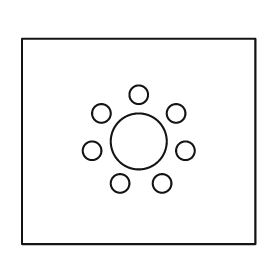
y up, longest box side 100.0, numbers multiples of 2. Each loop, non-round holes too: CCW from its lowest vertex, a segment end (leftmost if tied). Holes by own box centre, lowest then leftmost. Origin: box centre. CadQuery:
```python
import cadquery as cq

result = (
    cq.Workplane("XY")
    .moveTo(-50.0, -44.0)
    .lineTo(50.0, -44.0)
    .lineTo(50.0, 44.0)
    .lineTo(-50.0, 44.0)
    .close()
    .moveTo(-8.0, -18.0)
    .circle(4.0)
    .moveTo(10.0, -18.0)
    .circle(4.0)
    .moveTo(-20.0, -4.0)
    .circle(4.0)
    .moveTo(20.0, -4.0)
    .circle(4.0)
    .moveTo(0.0, 0.0)
    .circle(12.0)
    .moveTo(-16.0, 12.0)
    .circle(4.0)
    .moveTo(16.0, 12.0)
    .circle(4.0)
    .moveTo(0.0, 20.0)
    .circle(4.0)
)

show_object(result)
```